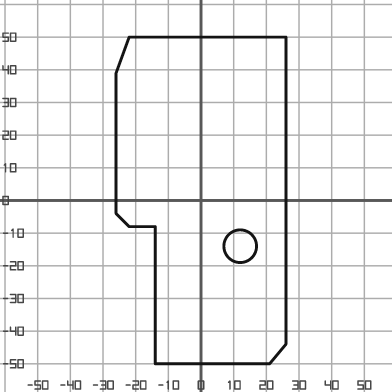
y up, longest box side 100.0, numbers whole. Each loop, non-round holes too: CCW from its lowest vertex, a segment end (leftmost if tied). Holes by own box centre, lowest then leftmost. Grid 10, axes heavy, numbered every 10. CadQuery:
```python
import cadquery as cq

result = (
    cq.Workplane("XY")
    .moveTo(-14.0, -50.0)
    .lineTo(21.0, -50.0)
    .lineTo(26.0, -44.0)
    .lineTo(26.0, 50.0)
    .lineTo(-22.0, 50.0)
    .lineTo(-26.0, 39.0)
    .lineTo(-26.0, -4.0)
    .lineTo(-22.0, -8.0)
    .lineTo(-14.0, -8.0)
    .close()
    .moveTo(12.0, -14.0)
    .circle(5.0)
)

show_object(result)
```